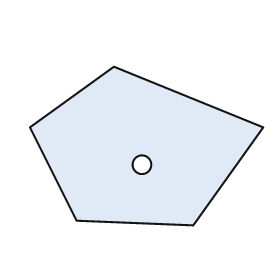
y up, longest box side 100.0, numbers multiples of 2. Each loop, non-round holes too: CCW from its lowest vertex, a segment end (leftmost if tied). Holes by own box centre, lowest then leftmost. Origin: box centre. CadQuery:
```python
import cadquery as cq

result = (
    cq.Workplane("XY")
    .moveTo(20.0, -34.0)
    .lineTo(50.0, 8.0)
    .lineTo(-14.0, 34.0)
    .lineTo(-50.0, 8.0)
    .lineTo(-30.0, -32.0)
    .close()
    .moveTo(-2.0, -8.0)
    .circle(4.0)
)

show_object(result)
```